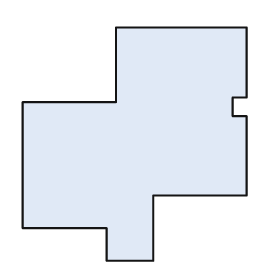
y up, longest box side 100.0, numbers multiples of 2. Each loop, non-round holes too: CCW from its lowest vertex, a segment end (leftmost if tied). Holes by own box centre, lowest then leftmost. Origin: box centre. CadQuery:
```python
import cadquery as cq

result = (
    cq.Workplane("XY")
    .moveTo(-12.0, -50.0)
    .lineTo(8.0, -50.0)
    .lineTo(8.0, -22.0)
    .lineTo(48.0, -22.0)
    .lineTo(48.0, 12.0)
    .lineTo(42.0, 12.0)
    .lineTo(42.0, 20.0)
    .lineTo(48.0, 20.0)
    .lineTo(48.0, 50.0)
    .lineTo(-8.0, 50.0)
    .lineTo(-8.0, 18.0)
    .lineTo(-48.0, 18.0)
    .lineTo(-48.0, -36.0)
    .lineTo(-12.0, -36.0)
    .close()
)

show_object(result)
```